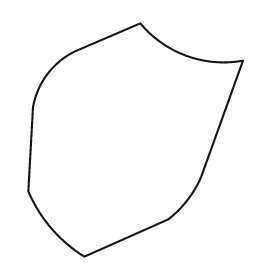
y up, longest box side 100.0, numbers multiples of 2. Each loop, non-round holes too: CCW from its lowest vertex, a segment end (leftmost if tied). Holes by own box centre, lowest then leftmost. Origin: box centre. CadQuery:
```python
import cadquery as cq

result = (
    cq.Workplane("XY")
    .moveTo(-22.0, -50.0)
    .lineTo(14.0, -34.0)
    .threePointArc((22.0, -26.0), (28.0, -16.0))
    .lineTo(46.0, 34.0)
    .threePointArc((22.0, 36.0), (2.0, 50.0))
    .lineTo(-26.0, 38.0)
    .threePointArc((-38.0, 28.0), (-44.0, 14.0))
    .lineTo(-46.0, -22.0)
    .threePointArc((-36.0, -38.0), (-22.0, -50.0))
    .close()
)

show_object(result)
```